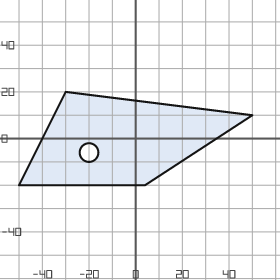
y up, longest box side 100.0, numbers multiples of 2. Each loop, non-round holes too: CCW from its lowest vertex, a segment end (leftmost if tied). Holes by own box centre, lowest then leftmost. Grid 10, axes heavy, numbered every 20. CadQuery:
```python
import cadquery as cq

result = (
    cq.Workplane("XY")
    .moveTo(-50.0, -20.0)
    .lineTo(4.0, -20.0)
    .lineTo(50.0, 10.0)
    .lineTo(-30.0, 20.0)
    .close()
    .moveTo(-20.0, -6.0)
    .circle(4.0)
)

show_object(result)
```